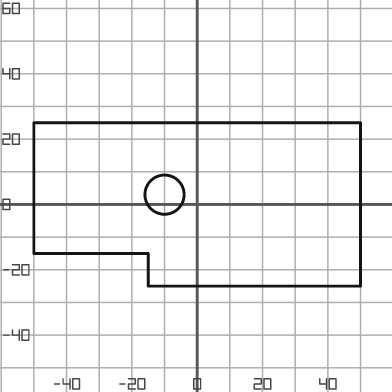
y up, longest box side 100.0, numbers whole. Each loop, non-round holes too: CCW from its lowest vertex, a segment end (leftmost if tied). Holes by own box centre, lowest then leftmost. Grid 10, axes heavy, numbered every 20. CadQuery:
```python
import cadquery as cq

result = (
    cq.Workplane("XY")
    .moveTo(-15.0, -25.0)
    .lineTo(50.0, -25.0)
    .lineTo(50.0, 25.0)
    .lineTo(-50.0, 25.0)
    .lineTo(-50.0, -15.0)
    .lineTo(-15.0, -15.0)
    .close()
    .moveTo(-10.0, 3.0)
    .circle(6.0)
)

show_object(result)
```